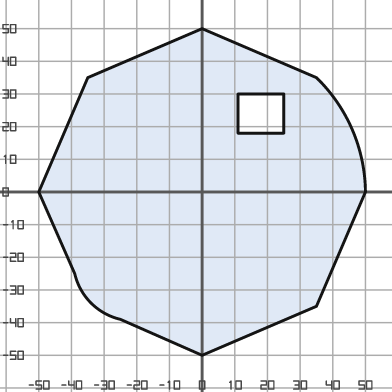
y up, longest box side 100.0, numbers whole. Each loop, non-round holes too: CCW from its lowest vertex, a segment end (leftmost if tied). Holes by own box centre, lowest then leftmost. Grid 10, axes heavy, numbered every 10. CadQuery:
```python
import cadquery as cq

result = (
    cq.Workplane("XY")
    .moveTo(0.0, -50.0)
    .lineTo(35.0, -35.0)
    .lineTo(50.0, 0.0)
    .threePointArc((46.0, 19.0), (35.0, 35.0))
    .lineTo(0.0, 50.0)
    .lineTo(-35.0, 35.0)
    .lineTo(-50.0, 0.0)
    .lineTo(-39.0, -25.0)
    .threePointArc((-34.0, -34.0), (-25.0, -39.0))
    .close()
    .moveTo(11.0, 18.0)
    .lineTo(25.0, 18.0)
    .lineTo(25.0, 30.0)
    .lineTo(11.0, 30.0)
    .close()
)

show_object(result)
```